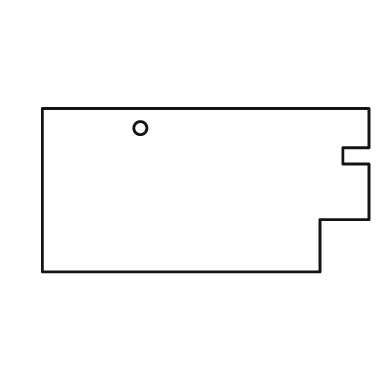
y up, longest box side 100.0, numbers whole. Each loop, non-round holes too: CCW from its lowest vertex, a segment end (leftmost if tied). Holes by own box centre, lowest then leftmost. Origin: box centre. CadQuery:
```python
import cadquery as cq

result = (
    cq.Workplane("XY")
    .moveTo(-50.0, -25.0)
    .lineTo(35.0, -25.0)
    .lineTo(35.0, -9.0)
    .lineTo(50.0, -9.0)
    .lineTo(50.0, 8.0)
    .lineTo(42.0, 8.0)
    .lineTo(42.0, 13.0)
    .lineTo(50.0, 13.0)
    .lineTo(50.0, 25.0)
    .lineTo(-50.0, 25.0)
    .close()
    .moveTo(-20.0, 19.0)
    .circle(2.0)
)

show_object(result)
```